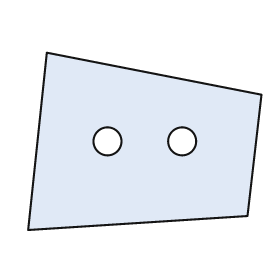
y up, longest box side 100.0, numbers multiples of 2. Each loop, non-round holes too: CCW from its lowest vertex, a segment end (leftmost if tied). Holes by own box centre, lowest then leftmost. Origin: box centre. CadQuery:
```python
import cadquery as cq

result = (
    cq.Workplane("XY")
    .moveTo(-50.0, -38.0)
    .lineTo(44.0, -32.0)
    .lineTo(50.0, 20.0)
    .lineTo(-42.0, 38.0)
    .close()
    .moveTo(-16.0, 0.0)
    .circle(6.0)
    .moveTo(16.0, 0.0)
    .circle(6.0)
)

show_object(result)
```